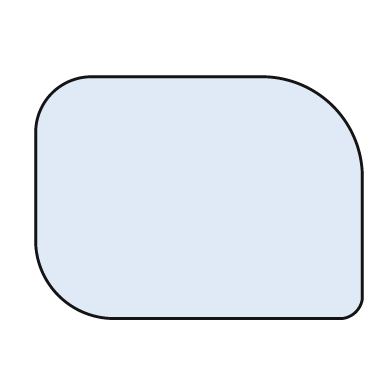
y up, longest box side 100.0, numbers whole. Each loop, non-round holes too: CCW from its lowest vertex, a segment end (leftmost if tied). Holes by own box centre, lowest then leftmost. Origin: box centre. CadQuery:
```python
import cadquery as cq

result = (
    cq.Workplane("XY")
    .moveTo(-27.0, -37.0)
    .lineTo(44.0, -37.0)
    .threePointArc((48.0, -35.0), (50.0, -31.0))
    .lineTo(50.0, 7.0)
    .threePointArc((41.0, 28.0), (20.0, 37.0))
    .lineTo(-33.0, 37.0)
    .threePointArc((-45.0, 32.0), (-50.0, 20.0))
    .lineTo(-50.0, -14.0)
    .threePointArc((-43.0, -30.0), (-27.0, -37.0))
    .close()
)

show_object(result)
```